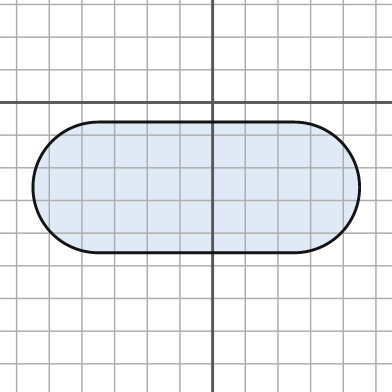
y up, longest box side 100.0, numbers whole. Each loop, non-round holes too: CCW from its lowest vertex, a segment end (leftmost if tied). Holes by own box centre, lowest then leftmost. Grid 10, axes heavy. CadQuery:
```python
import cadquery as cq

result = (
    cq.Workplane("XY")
    .moveTo(-35.0, -46.0)
    .lineTo(25.0, -46.0)
    .threePointArc((45.0, -26.0), (25.0, -6.0))
    .lineTo(-35.0, -6.0)
    .threePointArc((-55.0, -26.0), (-35.0, -46.0))
    .close()
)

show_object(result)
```